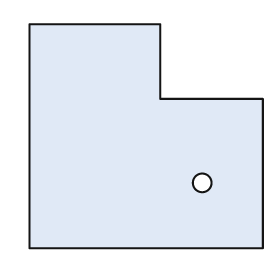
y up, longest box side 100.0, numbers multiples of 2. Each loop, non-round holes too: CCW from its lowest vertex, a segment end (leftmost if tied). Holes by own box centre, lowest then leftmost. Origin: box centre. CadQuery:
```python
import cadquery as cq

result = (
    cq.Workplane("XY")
    .moveTo(-50.0, -48.0)
    .lineTo(50.0, -48.0)
    .lineTo(50.0, 16.0)
    .lineTo(6.0, 16.0)
    .lineTo(6.0, 48.0)
    .lineTo(-50.0, 48.0)
    .close()
    .moveTo(24.0, -20.0)
    .circle(4.0)
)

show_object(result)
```